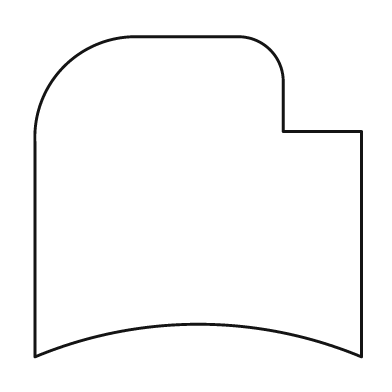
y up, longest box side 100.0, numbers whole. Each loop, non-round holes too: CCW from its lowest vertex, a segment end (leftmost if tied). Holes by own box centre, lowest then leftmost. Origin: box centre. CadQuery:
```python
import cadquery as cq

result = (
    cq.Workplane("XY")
    .moveTo(-50.0, -49.0)
    .threePointArc((0.0, -39.0), (50.0, -49.0))
    .lineTo(50.0, 20.0)
    .lineTo(26.0, 20.0)
    .lineTo(26.0, 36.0)
    .threePointArc((22.0, 45.0), (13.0, 49.0))
    .lineTo(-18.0, 49.0)
    .threePointArc((-41.0, 40.0), (-50.0, 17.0))
    .close()
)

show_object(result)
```